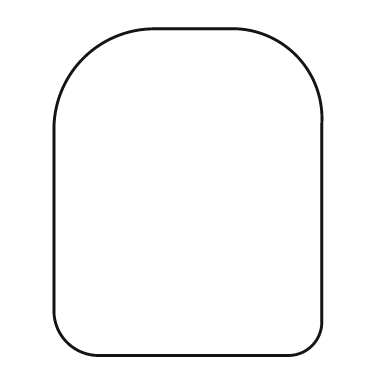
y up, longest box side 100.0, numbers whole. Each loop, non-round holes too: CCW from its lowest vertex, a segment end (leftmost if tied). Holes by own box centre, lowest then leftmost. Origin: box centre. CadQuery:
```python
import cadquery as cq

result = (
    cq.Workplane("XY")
    .moveTo(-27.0, -50.0)
    .lineTo(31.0, -50.0)
    .threePointArc((38.0, -47.0), (41.0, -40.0))
    .lineTo(41.0, 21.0)
    .threePointArc((33.0, 42.0), (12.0, 50.0))
    .lineTo(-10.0, 50.0)
    .threePointArc((-32.0, 41.0), (-41.0, 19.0))
    .lineTo(-41.0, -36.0)
    .threePointArc((-37.0, -46.0), (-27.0, -50.0))
    .close()
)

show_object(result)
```